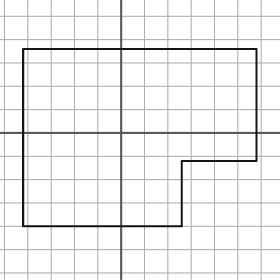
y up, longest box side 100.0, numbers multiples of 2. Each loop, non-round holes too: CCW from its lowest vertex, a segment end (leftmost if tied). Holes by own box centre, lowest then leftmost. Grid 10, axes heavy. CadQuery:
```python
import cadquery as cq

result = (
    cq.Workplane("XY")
    .moveTo(-42.0, -40.0)
    .lineTo(26.0, -40.0)
    .lineTo(26.0, -12.0)
    .lineTo(58.0, -12.0)
    .lineTo(58.0, 36.0)
    .lineTo(-42.0, 36.0)
    .close()
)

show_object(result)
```